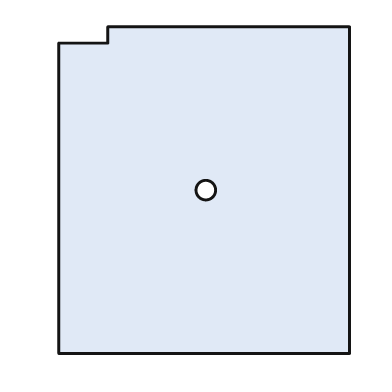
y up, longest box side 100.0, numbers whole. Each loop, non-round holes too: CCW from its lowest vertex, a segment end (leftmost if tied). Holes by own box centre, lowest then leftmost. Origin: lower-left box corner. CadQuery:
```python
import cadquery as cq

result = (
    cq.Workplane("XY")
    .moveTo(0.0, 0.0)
    .lineTo(89.0, 0.0)
    .lineTo(89.0, 100.0)
    .lineTo(15.0, 100.0)
    .lineTo(15.0, 95.0)
    .lineTo(0.0, 95.0)
    .close()
    .moveTo(45.0, 50.0)
    .circle(3.0)
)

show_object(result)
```